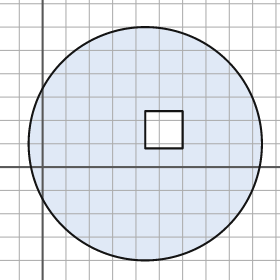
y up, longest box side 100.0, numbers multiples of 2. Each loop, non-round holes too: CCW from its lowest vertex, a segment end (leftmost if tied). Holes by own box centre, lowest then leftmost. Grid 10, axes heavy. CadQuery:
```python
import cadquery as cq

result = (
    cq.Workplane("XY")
    .moveTo(44.0, 10.0)
    .circle(50.0)
    .moveTo(44.0, 8.0)
    .lineTo(60.0, 8.0)
    .lineTo(60.0, 24.0)
    .lineTo(44.0, 24.0)
    .close()
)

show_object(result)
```